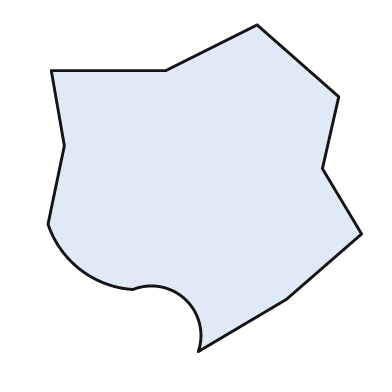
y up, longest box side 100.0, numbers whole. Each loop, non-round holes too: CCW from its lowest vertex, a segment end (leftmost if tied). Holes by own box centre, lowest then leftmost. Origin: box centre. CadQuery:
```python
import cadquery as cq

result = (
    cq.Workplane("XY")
    .moveTo(-2.0, -50.0)
    .lineTo(25.0, -34.0)
    .lineTo(48.0, -14.0)
    .lineTo(36.0, 6.0)
    .lineTo(41.0, 28.0)
    .lineTo(16.0, 50.0)
    .lineTo(-12.0, 36.0)
    .lineTo(-47.0, 36.0)
    .lineTo(-43.0, 13.0)
    .lineTo(-48.0, -11.0)
    .threePointArc((-38.0, -25.0), (-22.0, -31.0))
    .threePointArc((-6.0, -34.0), (-2.0, -50.0))
    .close()
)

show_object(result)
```